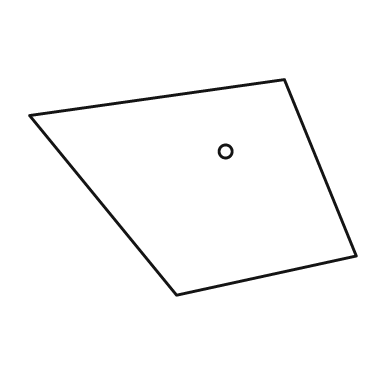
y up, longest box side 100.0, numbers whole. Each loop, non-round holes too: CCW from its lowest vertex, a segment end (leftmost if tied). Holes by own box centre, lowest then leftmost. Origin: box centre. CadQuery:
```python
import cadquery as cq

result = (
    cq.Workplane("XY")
    .moveTo(-5.0, -33.0)
    .lineTo(50.0, -21.0)
    .lineTo(28.0, 33.0)
    .lineTo(-50.0, 22.0)
    .close()
    .moveTo(10.0, 11.0)
    .circle(2.0)
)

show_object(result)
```